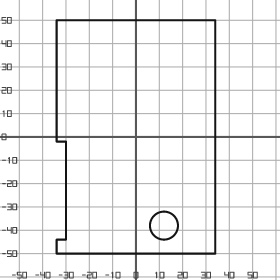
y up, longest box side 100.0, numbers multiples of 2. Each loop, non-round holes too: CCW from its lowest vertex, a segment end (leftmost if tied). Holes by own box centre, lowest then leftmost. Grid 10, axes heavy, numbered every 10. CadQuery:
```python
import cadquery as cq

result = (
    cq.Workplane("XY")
    .moveTo(-34.0, -50.0)
    .lineTo(34.0, -50.0)
    .lineTo(34.0, 50.0)
    .lineTo(-34.0, 50.0)
    .lineTo(-34.0, -2.0)
    .lineTo(-30.0, -2.0)
    .lineTo(-30.0, -44.0)
    .lineTo(-34.0, -44.0)
    .close()
    .moveTo(12.0, -38.0)
    .circle(6.0)
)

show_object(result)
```